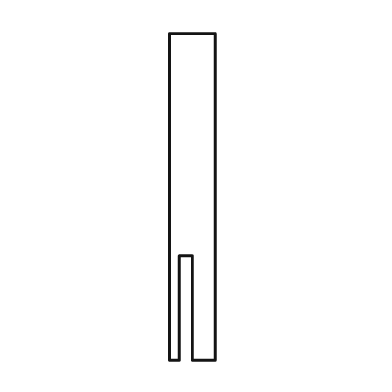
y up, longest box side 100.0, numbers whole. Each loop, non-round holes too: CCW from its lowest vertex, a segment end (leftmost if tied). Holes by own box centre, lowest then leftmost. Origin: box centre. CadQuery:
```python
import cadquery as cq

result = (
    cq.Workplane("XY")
    .moveTo(-7.0, -50.0)
    .lineTo(-4.0, -50.0)
    .lineTo(-4.0, -18.0)
    .lineTo(0.0, -18.0)
    .lineTo(0.0, -50.0)
    .lineTo(7.0, -50.0)
    .lineTo(7.0, 50.0)
    .lineTo(-7.0, 50.0)
    .close()
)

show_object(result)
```